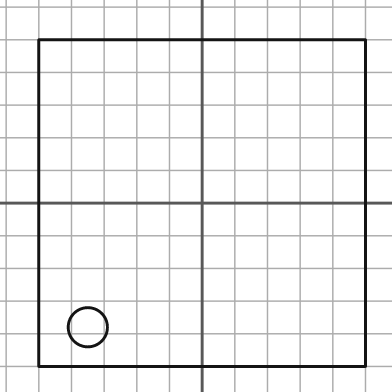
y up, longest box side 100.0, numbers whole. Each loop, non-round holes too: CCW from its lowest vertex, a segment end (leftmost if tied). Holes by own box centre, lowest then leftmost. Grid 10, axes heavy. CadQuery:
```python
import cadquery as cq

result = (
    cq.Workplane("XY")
    .moveTo(-50.0, -50.0)
    .lineTo(50.0, -50.0)
    .lineTo(50.0, 50.0)
    .lineTo(-50.0, 50.0)
    .close()
    .moveTo(-35.0, -38.0)
    .circle(6.0)
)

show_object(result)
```